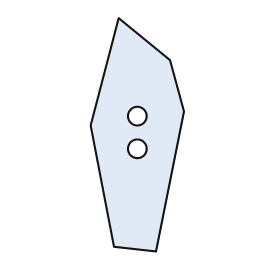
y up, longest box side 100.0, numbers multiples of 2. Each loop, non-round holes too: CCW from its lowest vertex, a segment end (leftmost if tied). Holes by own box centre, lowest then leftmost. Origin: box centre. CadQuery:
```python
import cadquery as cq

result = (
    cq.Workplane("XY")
    .moveTo(8.0, -50.0)
    .lineTo(20.0, 10.0)
    .lineTo(14.0, 32.0)
    .lineTo(-8.0, 50.0)
    .lineTo(-20.0, 4.0)
    .lineTo(-10.0, -48.0)
    .close()
    .moveTo(0.0, -6.0)
    .circle(4.0)
    .moveTo(0.0, 8.0)
    .circle(4.0)
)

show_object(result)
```